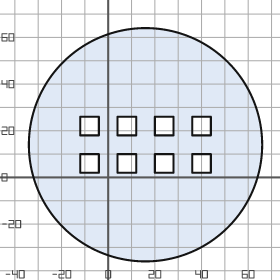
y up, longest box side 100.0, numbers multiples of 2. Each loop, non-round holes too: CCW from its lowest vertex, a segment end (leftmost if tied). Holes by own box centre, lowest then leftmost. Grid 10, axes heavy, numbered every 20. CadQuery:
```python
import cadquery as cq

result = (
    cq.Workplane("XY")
    .moveTo(16.0, 14.0)
    .circle(50.0)
    .moveTo(-12.0, 2.0)
    .lineTo(-4.0, 2.0)
    .lineTo(-4.0, 10.0)
    .lineTo(-12.0, 10.0)
    .close()
    .moveTo(4.0, 2.0)
    .lineTo(12.0, 2.0)
    .lineTo(12.0, 10.0)
    .lineTo(4.0, 10.0)
    .close()
    .moveTo(20.0, 2.0)
    .lineTo(28.0, 2.0)
    .lineTo(28.0, 10.0)
    .lineTo(20.0, 10.0)
    .close()
    .moveTo(36.0, 2.0)
    .lineTo(44.0, 2.0)
    .lineTo(44.0, 10.0)
    .lineTo(36.0, 10.0)
    .close()
    .moveTo(-12.0, 18.0)
    .lineTo(-4.0, 18.0)
    .lineTo(-4.0, 26.0)
    .lineTo(-12.0, 26.0)
    .close()
    .moveTo(4.0, 18.0)
    .lineTo(12.0, 18.0)
    .lineTo(12.0, 26.0)
    .lineTo(4.0, 26.0)
    .close()
    .moveTo(20.0, 18.0)
    .lineTo(28.0, 18.0)
    .lineTo(28.0, 26.0)
    .lineTo(20.0, 26.0)
    .close()
    .moveTo(36.0, 18.0)
    .lineTo(44.0, 18.0)
    .lineTo(44.0, 26.0)
    .lineTo(36.0, 26.0)
    .close()
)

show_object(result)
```